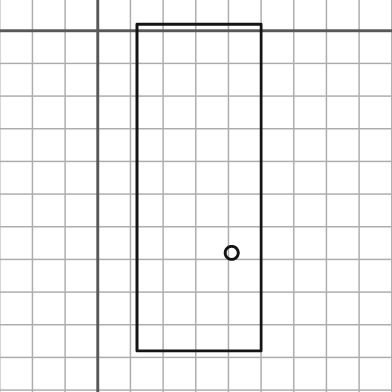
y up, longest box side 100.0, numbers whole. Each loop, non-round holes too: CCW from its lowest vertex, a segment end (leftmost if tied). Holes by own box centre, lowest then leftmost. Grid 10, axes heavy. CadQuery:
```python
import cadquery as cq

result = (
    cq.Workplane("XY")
    .moveTo(12.0, -98.0)
    .lineTo(50.0, -98.0)
    .lineTo(50.0, 2.0)
    .lineTo(12.0, 2.0)
    .close()
    .moveTo(41.0, -68.0)
    .circle(2.0)
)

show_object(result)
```